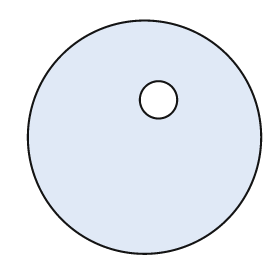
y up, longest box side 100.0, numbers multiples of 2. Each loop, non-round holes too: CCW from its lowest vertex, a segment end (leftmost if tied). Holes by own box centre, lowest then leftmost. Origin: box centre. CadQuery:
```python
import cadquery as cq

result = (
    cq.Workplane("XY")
    .moveTo(0.0, 0.0)
    .circle(50.0)
    .moveTo(6.0, 16.0)
    .circle(8.0)
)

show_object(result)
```